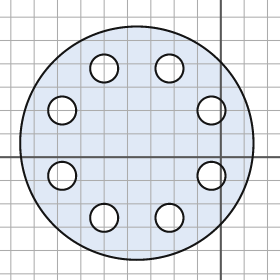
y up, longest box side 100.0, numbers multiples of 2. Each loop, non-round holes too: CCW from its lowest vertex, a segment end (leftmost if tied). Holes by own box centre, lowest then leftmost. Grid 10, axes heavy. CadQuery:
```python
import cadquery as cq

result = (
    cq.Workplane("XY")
    .moveTo(-36.0, 6.0)
    .circle(50.0)
    .moveTo(-50.0, -26.0)
    .circle(6.0)
    .moveTo(-22.0, -26.0)
    .circle(6.0)
    .moveTo(-68.0, -8.0)
    .circle(6.0)
    .moveTo(-4.0, -8.0)
    .circle(6.0)
    .moveTo(-68.0, 20.0)
    .circle(6.0)
    .moveTo(-4.0, 20.0)
    .circle(6.0)
    .moveTo(-50.0, 38.0)
    .circle(6.0)
    .moveTo(-22.0, 38.0)
    .circle(6.0)
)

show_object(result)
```